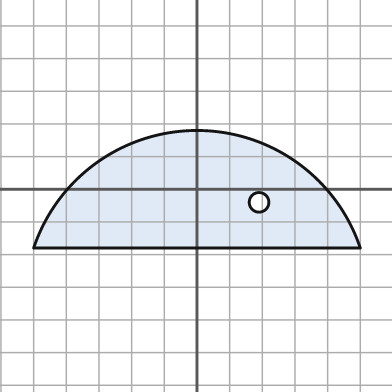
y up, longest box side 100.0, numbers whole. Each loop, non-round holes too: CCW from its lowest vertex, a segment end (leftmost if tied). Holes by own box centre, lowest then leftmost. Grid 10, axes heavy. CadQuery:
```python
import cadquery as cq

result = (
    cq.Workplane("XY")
    .moveTo(-50.0, -18.0)
    .lineTo(50.0, -18.0)
    .threePointArc((0.0, 18.0), (-50.0, -18.0))
    .close()
    .moveTo(19.0, -4.0)
    .circle(3.0)
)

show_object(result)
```